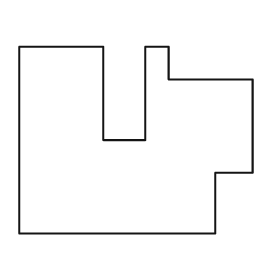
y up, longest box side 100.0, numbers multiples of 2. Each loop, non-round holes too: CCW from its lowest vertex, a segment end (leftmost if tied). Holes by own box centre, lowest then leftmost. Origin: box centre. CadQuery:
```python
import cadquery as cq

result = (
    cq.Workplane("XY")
    .moveTo(-50.0, -40.0)
    .lineTo(34.0, -40.0)
    .lineTo(34.0, -14.0)
    .lineTo(50.0, -14.0)
    .lineTo(50.0, 26.0)
    .lineTo(14.0, 26.0)
    .lineTo(14.0, 40.0)
    .lineTo(4.0, 40.0)
    .lineTo(4.0, 0.0)
    .lineTo(-14.0, 0.0)
    .lineTo(-14.0, 40.0)
    .lineTo(-50.0, 40.0)
    .close()
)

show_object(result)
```